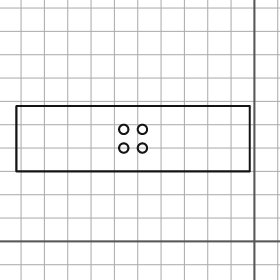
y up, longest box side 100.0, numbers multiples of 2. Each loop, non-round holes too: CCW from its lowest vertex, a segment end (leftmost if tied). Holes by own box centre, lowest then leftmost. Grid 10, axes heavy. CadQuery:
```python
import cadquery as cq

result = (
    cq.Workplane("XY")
    .moveTo(-102.0, 30.0)
    .lineTo(-2.0, 30.0)
    .lineTo(-2.0, 58.0)
    .lineTo(-102.0, 58.0)
    .close()
    .moveTo(-56.0, 40.0)
    .circle(2.0)
    .moveTo(-48.0, 40.0)
    .circle(2.0)
    .moveTo(-56.0, 48.0)
    .circle(2.0)
    .moveTo(-48.0, 48.0)
    .circle(2.0)
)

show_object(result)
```